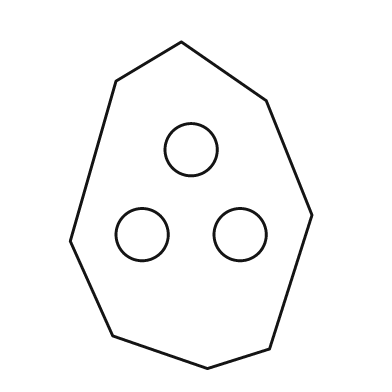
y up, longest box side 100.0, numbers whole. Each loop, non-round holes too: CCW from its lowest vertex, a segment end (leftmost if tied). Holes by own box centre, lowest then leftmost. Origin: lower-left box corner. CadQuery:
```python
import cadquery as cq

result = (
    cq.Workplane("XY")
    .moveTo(42.0, 0.0)
    .lineTo(61.0, 6.0)
    .lineTo(74.0, 47.0)
    .lineTo(60.0, 82.0)
    .lineTo(34.0, 100.0)
    .lineTo(14.0, 88.0)
    .lineTo(0.0, 39.0)
    .lineTo(13.0, 10.0)
    .close()
    .moveTo(22.0, 41.0)
    .circle(8.0)
    .moveTo(52.0, 41.0)
    .circle(8.0)
    .moveTo(37.0, 67.0)
    .circle(8.0)
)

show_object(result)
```